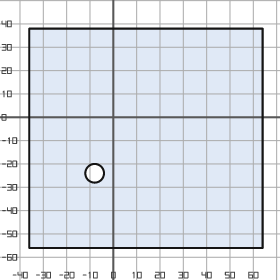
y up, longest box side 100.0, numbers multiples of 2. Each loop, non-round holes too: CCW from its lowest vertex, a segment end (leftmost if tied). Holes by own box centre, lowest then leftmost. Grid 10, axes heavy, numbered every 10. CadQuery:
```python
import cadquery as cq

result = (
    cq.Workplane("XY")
    .moveTo(-36.0, -56.0)
    .lineTo(64.0, -56.0)
    .lineTo(64.0, 38.0)
    .lineTo(-36.0, 38.0)
    .close()
    .moveTo(-8.0, -24.0)
    .circle(4.0)
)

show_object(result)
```